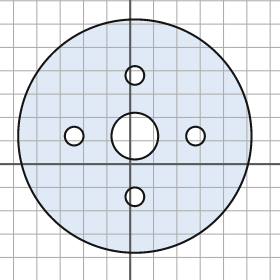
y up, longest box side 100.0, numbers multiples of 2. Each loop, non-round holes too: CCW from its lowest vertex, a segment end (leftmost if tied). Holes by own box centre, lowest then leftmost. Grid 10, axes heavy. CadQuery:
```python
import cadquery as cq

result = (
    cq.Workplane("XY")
    .moveTo(2.0, 12.0)
    .circle(50.0)
    .moveTo(2.0, -14.0)
    .circle(4.0)
    .moveTo(-24.0, 12.0)
    .circle(4.0)
    .moveTo(2.0, 12.0)
    .circle(10.0)
    .moveTo(28.0, 12.0)
    .circle(4.0)
    .moveTo(2.0, 38.0)
    .circle(4.0)
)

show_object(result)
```